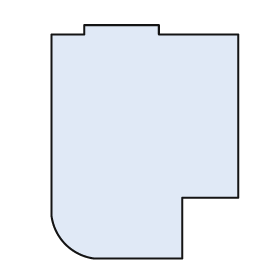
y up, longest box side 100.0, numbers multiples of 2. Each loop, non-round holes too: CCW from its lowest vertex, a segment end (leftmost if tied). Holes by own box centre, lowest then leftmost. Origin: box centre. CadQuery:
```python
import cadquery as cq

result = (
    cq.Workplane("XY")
    .moveTo(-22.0, -50.0)
    .lineTo(16.0, -50.0)
    .lineTo(16.0, -24.0)
    .lineTo(40.0, -24.0)
    .lineTo(40.0, 46.0)
    .lineTo(6.0, 46.0)
    .lineTo(6.0, 50.0)
    .lineTo(-26.0, 50.0)
    .lineTo(-26.0, 46.0)
    .lineTo(-40.0, 46.0)
    .lineTo(-40.0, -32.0)
    .threePointArc((-34.0, -44.0), (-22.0, -50.0))
    .close()
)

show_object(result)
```